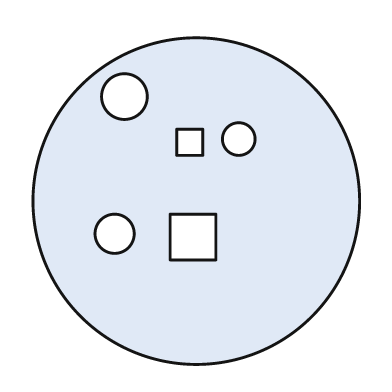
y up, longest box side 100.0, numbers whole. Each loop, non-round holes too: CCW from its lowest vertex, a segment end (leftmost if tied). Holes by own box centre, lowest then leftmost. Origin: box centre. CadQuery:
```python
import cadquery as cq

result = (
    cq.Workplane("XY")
    .moveTo(0.0, 0.0)
    .circle(50.0)
    .moveTo(-8.0, -18.0)
    .lineTo(6.0, -18.0)
    .lineTo(6.0, -4.0)
    .lineTo(-8.0, -4.0)
    .close()
    .moveTo(-25.0, -10.0)
    .circle(6.0)
    .moveTo(-6.0, 14.0)
    .lineTo(2.0, 14.0)
    .lineTo(2.0, 22.0)
    .lineTo(-6.0, 22.0)
    .close()
    .moveTo(13.0, 19.0)
    .circle(5.0)
    .moveTo(-22.0, 32.0)
    .circle(7.0)
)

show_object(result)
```